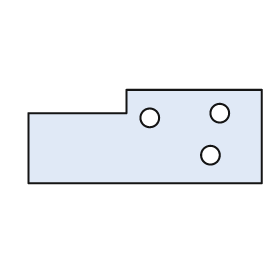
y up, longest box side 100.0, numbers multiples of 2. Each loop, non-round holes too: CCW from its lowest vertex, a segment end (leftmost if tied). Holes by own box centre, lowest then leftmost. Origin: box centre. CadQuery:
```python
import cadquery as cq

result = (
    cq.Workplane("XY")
    .moveTo(-50.0, -20.0)
    .lineTo(50.0, -20.0)
    .lineTo(50.0, 20.0)
    .lineTo(-8.0, 20.0)
    .lineTo(-8.0, 10.0)
    .lineTo(-50.0, 10.0)
    .close()
    .moveTo(28.0, -8.0)
    .circle(4.0)
    .moveTo(2.0, 8.0)
    .circle(4.0)
    .moveTo(32.0, 10.0)
    .circle(4.0)
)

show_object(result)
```